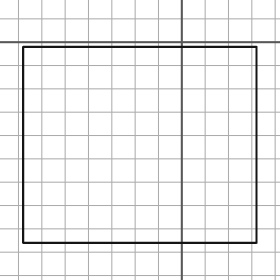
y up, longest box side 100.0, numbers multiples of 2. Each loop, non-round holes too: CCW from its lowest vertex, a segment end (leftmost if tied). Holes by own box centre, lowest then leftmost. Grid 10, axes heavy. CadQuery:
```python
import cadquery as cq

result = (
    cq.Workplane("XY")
    .moveTo(-68.0, -86.0)
    .lineTo(32.0, -86.0)
    .lineTo(32.0, -2.0)
    .lineTo(-68.0, -2.0)
    .close()
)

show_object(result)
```